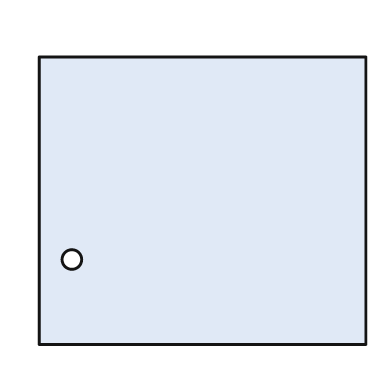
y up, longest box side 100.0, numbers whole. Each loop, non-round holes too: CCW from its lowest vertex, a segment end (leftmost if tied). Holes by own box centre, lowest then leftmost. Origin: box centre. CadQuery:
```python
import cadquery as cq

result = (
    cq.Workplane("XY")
    .moveTo(-50.0, -44.0)
    .lineTo(50.0, -44.0)
    .lineTo(50.0, 44.0)
    .lineTo(-50.0, 44.0)
    .close()
    .moveTo(-40.0, -18.0)
    .circle(3.0)
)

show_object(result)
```